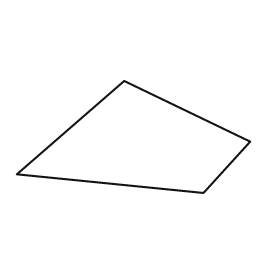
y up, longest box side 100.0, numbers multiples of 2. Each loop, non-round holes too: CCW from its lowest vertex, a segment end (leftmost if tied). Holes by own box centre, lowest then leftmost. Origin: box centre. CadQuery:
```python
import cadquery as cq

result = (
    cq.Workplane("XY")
    .moveTo(30.0, -24.0)
    .lineTo(50.0, -2.0)
    .lineTo(-4.0, 24.0)
    .lineTo(-50.0, -16.0)
    .close()
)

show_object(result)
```